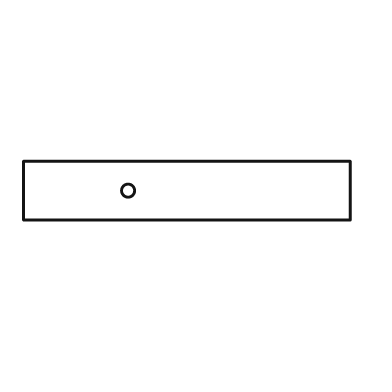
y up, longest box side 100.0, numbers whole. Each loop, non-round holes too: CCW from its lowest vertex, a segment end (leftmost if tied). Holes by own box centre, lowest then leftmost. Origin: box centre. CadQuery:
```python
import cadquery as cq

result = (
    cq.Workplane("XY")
    .moveTo(-50.0, -9.0)
    .lineTo(50.0, -9.0)
    .lineTo(50.0, 9.0)
    .lineTo(-50.0, 9.0)
    .close()
    .moveTo(-18.0, 0.0)
    .circle(2.0)
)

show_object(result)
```